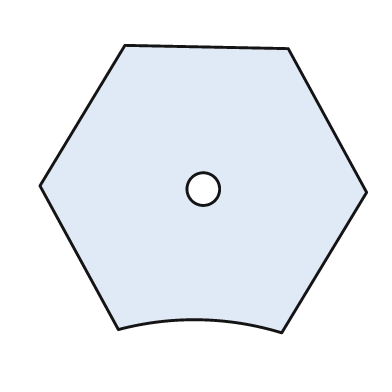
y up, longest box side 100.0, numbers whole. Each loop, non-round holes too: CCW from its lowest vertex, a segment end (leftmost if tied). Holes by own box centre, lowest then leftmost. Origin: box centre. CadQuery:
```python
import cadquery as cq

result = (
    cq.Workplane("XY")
    .moveTo(24.0, -44.0)
    .lineTo(50.0, -1.0)
    .lineTo(26.0, 43.0)
    .lineTo(-24.0, 44.0)
    .lineTo(-50.0, 1.0)
    .lineTo(-26.0, -43.0)
    .threePointArc((-1.0, -40.0), (24.0, -44.0))
    .close()
    .moveTo(0.0, 0.0)
    .circle(5.0)
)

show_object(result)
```